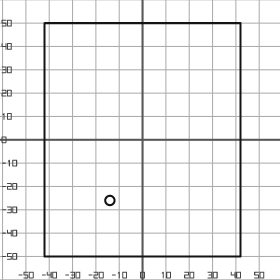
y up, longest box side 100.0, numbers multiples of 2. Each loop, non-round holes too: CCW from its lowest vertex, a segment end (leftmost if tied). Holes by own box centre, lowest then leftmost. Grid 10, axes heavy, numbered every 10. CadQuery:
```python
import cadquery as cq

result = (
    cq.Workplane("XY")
    .moveTo(-42.0, -50.0)
    .lineTo(42.0, -50.0)
    .lineTo(42.0, 50.0)
    .lineTo(-42.0, 50.0)
    .close()
    .moveTo(-14.0, -26.0)
    .circle(2.0)
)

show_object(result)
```